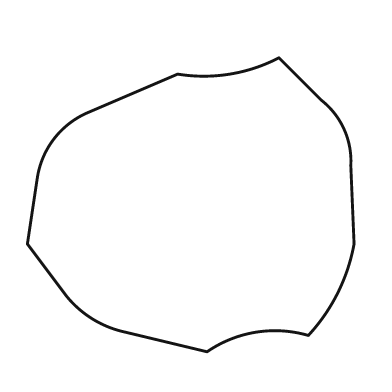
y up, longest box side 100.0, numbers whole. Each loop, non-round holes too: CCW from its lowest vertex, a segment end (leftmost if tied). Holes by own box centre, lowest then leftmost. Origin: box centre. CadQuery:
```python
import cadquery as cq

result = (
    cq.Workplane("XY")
    .moveTo(5.0, -45.0)
    .threePointArc((20.0, -39.0), (36.0, -40.0))
    .threePointArc((45.0, -27.0), (50.0, -12.0))
    .lineTo(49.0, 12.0)
    .threePointArc((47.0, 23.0), (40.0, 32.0))
    .lineTo(27.0, 45.0)
    .threePointArc((12.0, 40.0), (-4.0, 40.0))
    .lineTo(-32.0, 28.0)
    .threePointArc((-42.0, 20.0), (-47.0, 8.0))
    .lineTo(-50.0, -12.0)
    .lineTo(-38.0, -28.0)
    .threePointArc((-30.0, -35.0), (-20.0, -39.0))
    .close()
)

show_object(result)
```